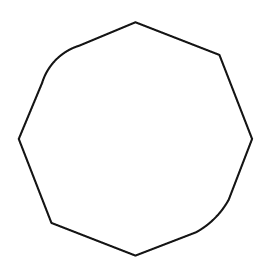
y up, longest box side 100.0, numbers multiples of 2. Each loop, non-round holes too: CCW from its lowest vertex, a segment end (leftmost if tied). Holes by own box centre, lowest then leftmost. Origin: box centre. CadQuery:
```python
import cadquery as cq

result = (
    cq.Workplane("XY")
    .moveTo(0.0, -50.0)
    .lineTo(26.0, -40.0)
    .threePointArc((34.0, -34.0), (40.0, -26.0))
    .lineTo(50.0, 0.0)
    .lineTo(36.0, 36.0)
    .lineTo(0.0, 50.0)
    .lineTo(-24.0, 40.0)
    .threePointArc((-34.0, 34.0), (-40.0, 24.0))
    .lineTo(-50.0, 0.0)
    .lineTo(-36.0, -36.0)
    .close()
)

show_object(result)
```